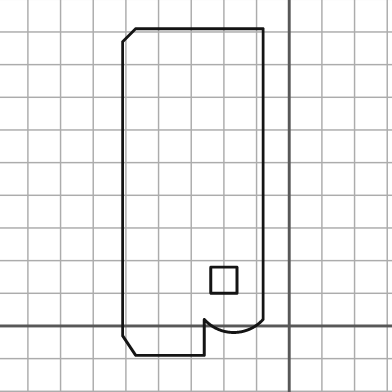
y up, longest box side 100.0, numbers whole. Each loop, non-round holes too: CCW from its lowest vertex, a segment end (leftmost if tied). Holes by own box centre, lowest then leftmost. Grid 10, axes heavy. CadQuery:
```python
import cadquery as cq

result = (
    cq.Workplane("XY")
    .moveTo(-47.0, -9.0)
    .lineTo(-26.0, -9.0)
    .lineTo(-26.0, 2.0)
    .threePointArc((-17.0, -2.0), (-8.0, 2.0))
    .lineTo(-8.0, 91.0)
    .lineTo(-47.0, 91.0)
    .lineTo(-51.0, 87.0)
    .lineTo(-51.0, -3.0)
    .close()
    .moveTo(-24.0, 10.0)
    .lineTo(-16.0, 10.0)
    .lineTo(-16.0, 18.0)
    .lineTo(-24.0, 18.0)
    .close()
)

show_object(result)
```